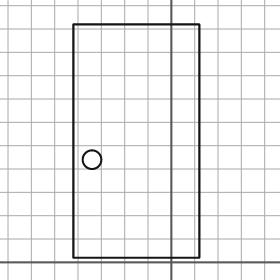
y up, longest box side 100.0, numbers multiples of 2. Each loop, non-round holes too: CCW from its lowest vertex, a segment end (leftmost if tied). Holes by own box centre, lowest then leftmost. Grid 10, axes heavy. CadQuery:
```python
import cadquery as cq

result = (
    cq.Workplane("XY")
    .moveTo(-42.0, 2.0)
    .lineTo(12.0, 2.0)
    .lineTo(12.0, 102.0)
    .lineTo(-42.0, 102.0)
    .close()
    .moveTo(-34.0, 44.0)
    .circle(4.0)
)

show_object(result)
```